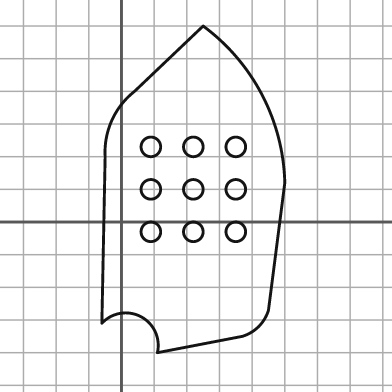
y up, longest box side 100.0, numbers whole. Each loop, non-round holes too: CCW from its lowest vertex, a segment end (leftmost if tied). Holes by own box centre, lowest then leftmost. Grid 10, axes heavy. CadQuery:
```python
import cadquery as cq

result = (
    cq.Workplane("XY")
    .moveTo(11.0, -40.0)
    .lineTo(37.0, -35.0)
    .threePointArc((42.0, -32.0), (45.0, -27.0))
    .lineTo(50.0, 12.0)
    .threePointArc((43.0, 39.0), (25.0, 60.0))
    .lineTo(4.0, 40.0)
    .threePointArc((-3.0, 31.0), (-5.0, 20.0))
    .lineTo(-6.0, -31.0)
    .threePointArc((6.0, -29.0), (11.0, -40.0))
    .close()
    .moveTo(9.0, -3.0)
    .circle(3.0)
    .moveTo(22.0, -3.0)
    .circle(3.0)
    .moveTo(35.0, -3.0)
    .circle(3.0)
    .moveTo(9.0, 10.0)
    .circle(3.0)
    .moveTo(22.0, 10.0)
    .circle(3.0)
    .moveTo(35.0, 10.0)
    .circle(3.0)
    .moveTo(9.0, 23.0)
    .circle(3.0)
    .moveTo(22.0, 23.0)
    .circle(3.0)
    .moveTo(35.0, 23.0)
    .circle(3.0)
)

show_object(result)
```